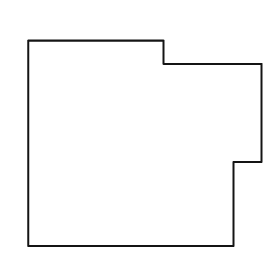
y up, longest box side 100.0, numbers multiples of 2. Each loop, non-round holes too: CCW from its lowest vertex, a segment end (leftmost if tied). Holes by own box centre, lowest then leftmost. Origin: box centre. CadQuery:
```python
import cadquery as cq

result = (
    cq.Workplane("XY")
    .moveTo(-50.0, -44.0)
    .lineTo(38.0, -44.0)
    .lineTo(38.0, -8.0)
    .lineTo(50.0, -8.0)
    .lineTo(50.0, 34.0)
    .lineTo(8.0, 34.0)
    .lineTo(8.0, 44.0)
    .lineTo(-50.0, 44.0)
    .close()
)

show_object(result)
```